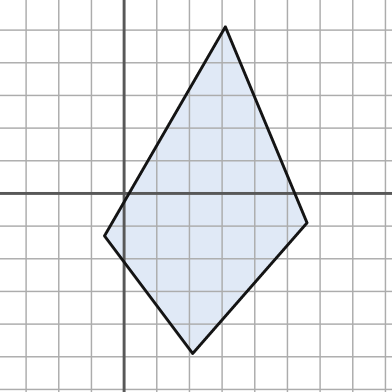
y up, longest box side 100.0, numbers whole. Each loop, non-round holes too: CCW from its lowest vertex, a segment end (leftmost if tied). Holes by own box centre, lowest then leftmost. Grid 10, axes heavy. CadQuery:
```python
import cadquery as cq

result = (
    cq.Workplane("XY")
    .moveTo(21.0, -49.0)
    .lineTo(56.0, -9.0)
    .lineTo(31.0, 51.0)
    .lineTo(-6.0, -13.0)
    .close()
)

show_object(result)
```